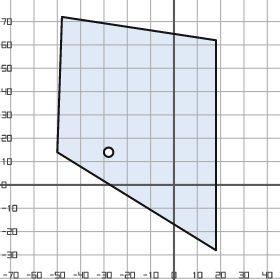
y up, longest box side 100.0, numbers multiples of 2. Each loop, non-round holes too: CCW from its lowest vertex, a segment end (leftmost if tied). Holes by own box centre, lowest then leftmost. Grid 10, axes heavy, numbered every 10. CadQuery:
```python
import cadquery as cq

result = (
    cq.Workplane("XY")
    .moveTo(18.0, -28.0)
    .lineTo(18.0, 62.0)
    .lineTo(-48.0, 72.0)
    .lineTo(-50.0, 14.0)
    .close()
    .moveTo(-28.0, 14.0)
    .circle(2.0)
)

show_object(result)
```